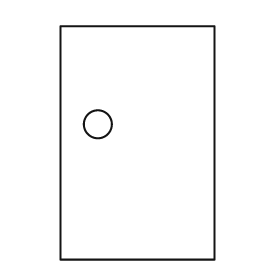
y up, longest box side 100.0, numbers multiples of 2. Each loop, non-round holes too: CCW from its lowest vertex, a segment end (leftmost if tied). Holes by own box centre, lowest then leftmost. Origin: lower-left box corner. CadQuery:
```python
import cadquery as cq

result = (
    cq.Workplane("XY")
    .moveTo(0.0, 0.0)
    .lineTo(66.0, 0.0)
    .lineTo(66.0, 100.0)
    .lineTo(0.0, 100.0)
    .close()
    .moveTo(16.0, 58.0)
    .circle(6.0)
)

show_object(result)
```